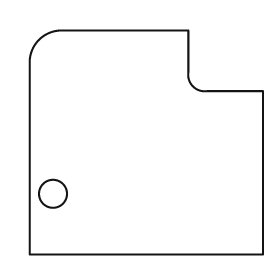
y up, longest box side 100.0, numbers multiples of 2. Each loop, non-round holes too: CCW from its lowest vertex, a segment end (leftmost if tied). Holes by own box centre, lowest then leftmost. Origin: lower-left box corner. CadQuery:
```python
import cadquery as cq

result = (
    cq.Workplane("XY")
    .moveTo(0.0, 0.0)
    .lineTo(100.0, 0.0)
    .lineTo(100.0, 70.0)
    .lineTo(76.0, 70.0)
    .threePointArc((70.0, 72.0), (68.0, 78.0))
    .lineTo(68.0, 96.0)
    .lineTo(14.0, 96.0)
    .threePointArc((4.0, 92.0), (0.0, 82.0))
    .close()
    .moveTo(10.0, 26.0)
    .circle(6.0)
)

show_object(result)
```